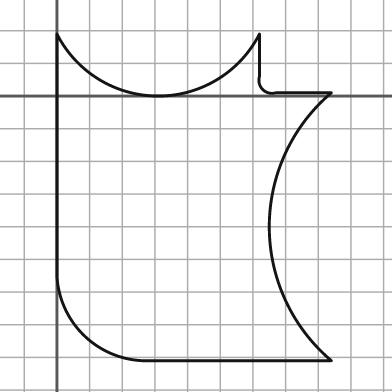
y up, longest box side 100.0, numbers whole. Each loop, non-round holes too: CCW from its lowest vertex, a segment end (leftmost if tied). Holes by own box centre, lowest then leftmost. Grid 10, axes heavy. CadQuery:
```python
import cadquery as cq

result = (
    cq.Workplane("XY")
    .moveTo(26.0, -81.0)
    .lineTo(84.0, -81.0)
    .threePointArc((65.0, -40.0), (84.0, 1.0))
    .lineTo(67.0, 1.0)
    .threePointArc((63.0, 2.0), (62.0, 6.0))
    .lineTo(62.0, 19.0)
    .threePointArc((31.0, 0.0), (0.0, 19.0))
    .lineTo(0.0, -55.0)
    .threePointArc((8.0, -73.0), (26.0, -81.0))
    .close()
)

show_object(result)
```